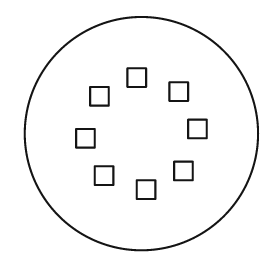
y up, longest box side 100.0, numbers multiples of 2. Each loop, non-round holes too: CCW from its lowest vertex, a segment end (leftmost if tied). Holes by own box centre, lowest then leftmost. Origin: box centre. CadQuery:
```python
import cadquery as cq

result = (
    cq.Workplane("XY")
    .moveTo(0.0, 0.0)
    .circle(50.0)
    .moveTo(-2.0, -28.0)
    .lineTo(6.0, -28.0)
    .lineTo(6.0, -20.0)
    .lineTo(-2.0, -20.0)
    .close()
    .moveTo(-20.0, -22.0)
    .lineTo(-12.0, -22.0)
    .lineTo(-12.0, -14.0)
    .lineTo(-20.0, -14.0)
    .close()
    .moveTo(14.0, -20.0)
    .lineTo(22.0, -20.0)
    .lineTo(22.0, -12.0)
    .lineTo(14.0, -12.0)
    .close()
    .moveTo(-28.0, -6.0)
    .lineTo(-20.0, -6.0)
    .lineTo(-20.0, 2.0)
    .lineTo(-28.0, 2.0)
    .close()
    .moveTo(20.0, -2.0)
    .lineTo(28.0, -2.0)
    .lineTo(28.0, 6.0)
    .lineTo(20.0, 6.0)
    .close()
    .moveTo(-22.0, 12.0)
    .lineTo(-14.0, 12.0)
    .lineTo(-14.0, 20.0)
    .lineTo(-22.0, 20.0)
    .close()
    .moveTo(12.0, 14.0)
    .lineTo(20.0, 14.0)
    .lineTo(20.0, 22.0)
    .lineTo(12.0, 22.0)
    .close()
    .moveTo(-6.0, 20.0)
    .lineTo(2.0, 20.0)
    .lineTo(2.0, 28.0)
    .lineTo(-6.0, 28.0)
    .close()
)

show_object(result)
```